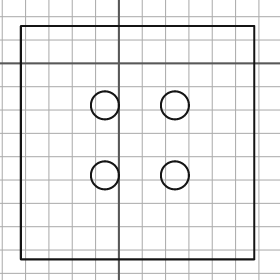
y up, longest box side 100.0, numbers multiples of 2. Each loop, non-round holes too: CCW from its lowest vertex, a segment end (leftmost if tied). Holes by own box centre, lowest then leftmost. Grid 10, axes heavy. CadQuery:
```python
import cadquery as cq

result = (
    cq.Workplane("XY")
    .moveTo(-42.0, -84.0)
    .lineTo(58.0, -84.0)
    .lineTo(58.0, 16.0)
    .lineTo(-42.0, 16.0)
    .close()
    .moveTo(-6.0, -48.0)
    .circle(6.0)
    .moveTo(24.0, -48.0)
    .circle(6.0)
    .moveTo(-6.0, -18.0)
    .circle(6.0)
    .moveTo(24.0, -18.0)
    .circle(6.0)
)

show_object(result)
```